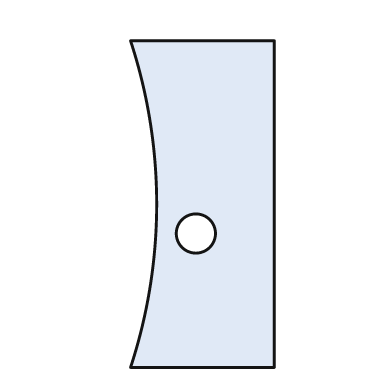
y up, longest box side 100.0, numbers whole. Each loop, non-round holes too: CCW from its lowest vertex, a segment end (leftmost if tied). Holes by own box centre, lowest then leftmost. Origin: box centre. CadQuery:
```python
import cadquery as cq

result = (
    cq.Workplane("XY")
    .moveTo(-22.0, -50.0)
    .lineTo(22.0, -50.0)
    .lineTo(22.0, 50.0)
    .lineTo(-22.0, 50.0)
    .threePointArc((-14.0, 0.0), (-22.0, -50.0))
    .close()
    .moveTo(-2.0, -9.0)
    .circle(6.0)
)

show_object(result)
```